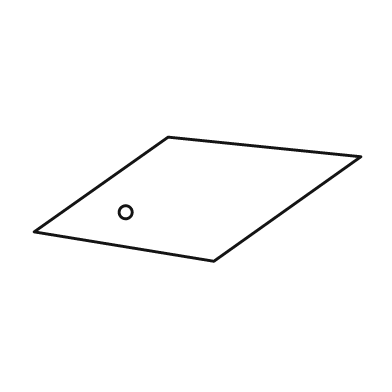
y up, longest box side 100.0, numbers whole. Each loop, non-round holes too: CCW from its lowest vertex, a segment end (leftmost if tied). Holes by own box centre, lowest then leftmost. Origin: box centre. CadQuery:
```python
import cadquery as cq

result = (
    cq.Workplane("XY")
    .moveTo(5.0, -19.0)
    .lineTo(50.0, 13.0)
    .lineTo(-9.0, 19.0)
    .lineTo(-50.0, -10.0)
    .close()
    .moveTo(-22.0, -4.0)
    .circle(2.0)
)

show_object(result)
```